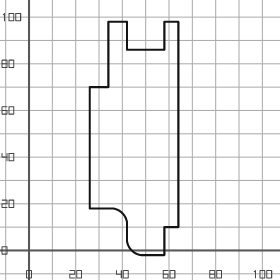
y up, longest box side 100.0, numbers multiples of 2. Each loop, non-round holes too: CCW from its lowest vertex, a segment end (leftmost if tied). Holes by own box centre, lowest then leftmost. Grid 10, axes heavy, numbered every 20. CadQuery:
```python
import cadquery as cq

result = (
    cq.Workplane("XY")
    .moveTo(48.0, -2.0)
    .lineTo(58.0, -2.0)
    .lineTo(58.0, 10.0)
    .lineTo(64.0, 10.0)
    .lineTo(64.0, 98.0)
    .lineTo(58.0, 98.0)
    .lineTo(58.0, 86.0)
    .lineTo(42.0, 86.0)
    .lineTo(42.0, 98.0)
    .lineTo(34.0, 98.0)
    .lineTo(34.0, 70.0)
    .lineTo(26.0, 70.0)
    .lineTo(26.0, 18.0)
    .lineTo(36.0, 18.0)
    .threePointArc((40.0, 16.0), (42.0, 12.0))
    .lineTo(42.0, 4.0)
    .threePointArc((44.0, 0.0), (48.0, -2.0))
    .close()
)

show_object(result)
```